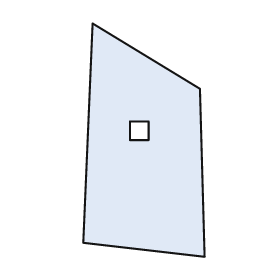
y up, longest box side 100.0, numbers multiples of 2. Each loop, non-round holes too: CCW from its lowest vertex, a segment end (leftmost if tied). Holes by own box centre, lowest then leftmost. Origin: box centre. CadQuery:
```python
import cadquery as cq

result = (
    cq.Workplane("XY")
    .moveTo(26.0, -50.0)
    .lineTo(24.0, 22.0)
    .lineTo(-22.0, 50.0)
    .lineTo(-26.0, -44.0)
    .close()
    .moveTo(-6.0, 0.0)
    .lineTo(2.0, 0.0)
    .lineTo(2.0, 8.0)
    .lineTo(-6.0, 8.0)
    .close()
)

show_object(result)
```